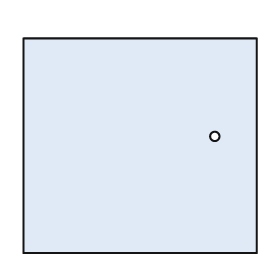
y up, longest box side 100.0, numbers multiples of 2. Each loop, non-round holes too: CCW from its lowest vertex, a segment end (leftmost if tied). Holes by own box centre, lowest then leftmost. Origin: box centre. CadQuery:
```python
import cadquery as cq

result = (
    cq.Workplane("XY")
    .moveTo(-50.0, -46.0)
    .lineTo(50.0, -46.0)
    .lineTo(50.0, 46.0)
    .lineTo(-50.0, 46.0)
    .close()
    .moveTo(32.0, 4.0)
    .circle(2.0)
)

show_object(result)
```